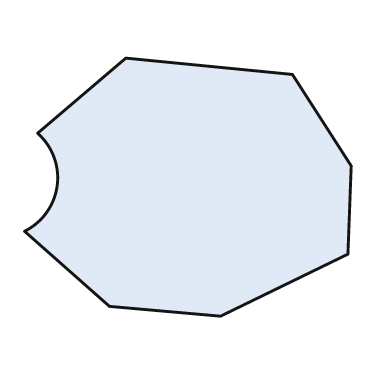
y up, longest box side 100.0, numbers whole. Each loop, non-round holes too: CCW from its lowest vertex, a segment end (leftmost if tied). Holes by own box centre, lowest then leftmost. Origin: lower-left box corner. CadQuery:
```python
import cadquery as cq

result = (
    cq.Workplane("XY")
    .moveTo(60.0, 0.0)
    .lineTo(99.0, 19.0)
    .lineTo(100.0, 46.0)
    .lineTo(82.0, 74.0)
    .lineTo(31.0, 79.0)
    .lineTo(4.0, 56.0)
    .threePointArc((10.0, 40.0), (0.0, 26.0))
    .lineTo(26.0, 3.0)
    .close()
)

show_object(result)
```